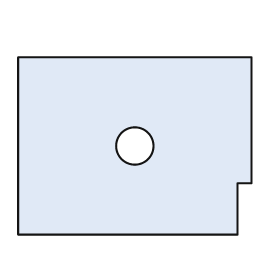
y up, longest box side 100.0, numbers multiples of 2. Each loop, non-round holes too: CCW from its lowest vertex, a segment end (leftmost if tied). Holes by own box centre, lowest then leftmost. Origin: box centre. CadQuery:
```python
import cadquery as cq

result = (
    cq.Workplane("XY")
    .moveTo(-50.0, -38.0)
    .lineTo(44.0, -38.0)
    .lineTo(44.0, -16.0)
    .lineTo(50.0, -16.0)
    .lineTo(50.0, 38.0)
    .lineTo(-50.0, 38.0)
    .close()
    .moveTo(0.0, 0.0)
    .circle(8.0)
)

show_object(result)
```